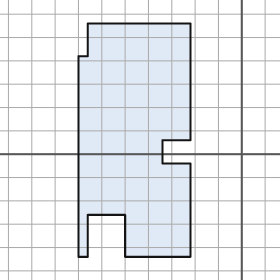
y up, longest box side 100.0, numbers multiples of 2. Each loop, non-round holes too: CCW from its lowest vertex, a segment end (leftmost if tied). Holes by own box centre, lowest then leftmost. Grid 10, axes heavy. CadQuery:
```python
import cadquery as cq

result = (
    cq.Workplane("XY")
    .moveTo(-70.0, -44.0)
    .lineTo(-66.0, -44.0)
    .lineTo(-66.0, -26.0)
    .lineTo(-50.0, -26.0)
    .lineTo(-50.0, -44.0)
    .lineTo(-22.0, -44.0)
    .lineTo(-22.0, -4.0)
    .lineTo(-34.0, -4.0)
    .lineTo(-34.0, 6.0)
    .lineTo(-22.0, 6.0)
    .lineTo(-22.0, 56.0)
    .lineTo(-66.0, 56.0)
    .lineTo(-66.0, 42.0)
    .lineTo(-70.0, 42.0)
    .close()
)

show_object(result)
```